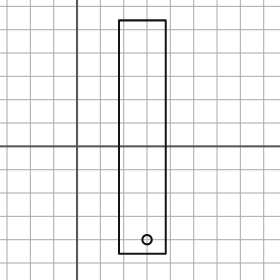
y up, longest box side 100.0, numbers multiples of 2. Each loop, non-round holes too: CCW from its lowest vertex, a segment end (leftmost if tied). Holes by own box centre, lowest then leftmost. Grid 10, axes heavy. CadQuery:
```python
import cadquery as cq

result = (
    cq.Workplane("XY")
    .moveTo(18.0, -46.0)
    .lineTo(38.0, -46.0)
    .lineTo(38.0, 54.0)
    .lineTo(18.0, 54.0)
    .close()
    .moveTo(30.0, -40.0)
    .circle(2.0)
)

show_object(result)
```